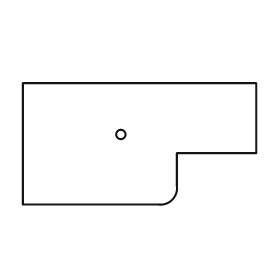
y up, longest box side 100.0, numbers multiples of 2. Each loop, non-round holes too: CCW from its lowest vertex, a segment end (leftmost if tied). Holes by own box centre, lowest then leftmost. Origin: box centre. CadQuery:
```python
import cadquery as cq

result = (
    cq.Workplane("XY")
    .moveTo(-50.0, -26.0)
    .lineTo(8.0, -26.0)
    .threePointArc((14.0, -24.0), (16.0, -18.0))
    .lineTo(16.0, -4.0)
    .lineTo(50.0, -4.0)
    .lineTo(50.0, 26.0)
    .lineTo(-50.0, 26.0)
    .close()
    .moveTo(-8.0, 4.0)
    .circle(2.0)
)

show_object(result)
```